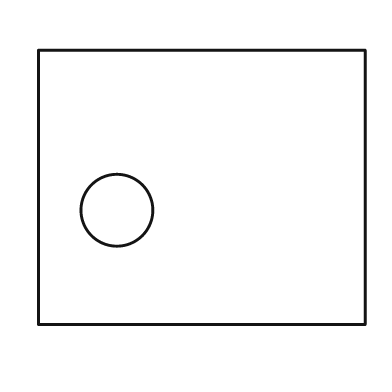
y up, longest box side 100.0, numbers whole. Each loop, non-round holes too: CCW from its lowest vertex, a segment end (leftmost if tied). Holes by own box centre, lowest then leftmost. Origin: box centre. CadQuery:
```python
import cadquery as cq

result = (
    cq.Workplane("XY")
    .moveTo(-50.0, -42.0)
    .lineTo(50.0, -42.0)
    .lineTo(50.0, 42.0)
    .lineTo(-50.0, 42.0)
    .close()
    .moveTo(-26.0, -7.0)
    .circle(11.0)
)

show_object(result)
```